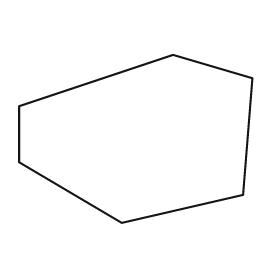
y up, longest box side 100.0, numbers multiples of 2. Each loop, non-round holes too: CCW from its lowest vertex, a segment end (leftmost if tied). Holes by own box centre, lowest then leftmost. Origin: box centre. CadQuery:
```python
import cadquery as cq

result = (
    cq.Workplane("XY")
    .moveTo(-6.0, -36.0)
    .lineTo(46.0, -24.0)
    .lineTo(50.0, 26.0)
    .lineTo(16.0, 36.0)
    .lineTo(-50.0, 14.0)
    .lineTo(-50.0, -10.0)
    .close()
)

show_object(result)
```